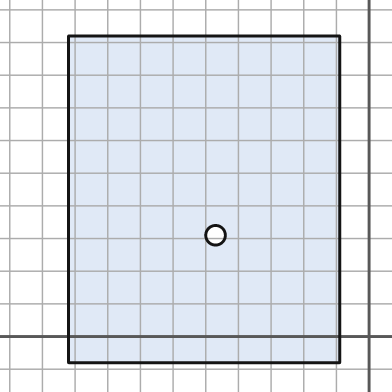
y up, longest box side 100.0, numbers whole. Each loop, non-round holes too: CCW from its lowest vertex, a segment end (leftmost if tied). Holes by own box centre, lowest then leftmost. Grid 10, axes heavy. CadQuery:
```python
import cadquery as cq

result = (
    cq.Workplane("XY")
    .moveTo(-92.0, -8.0)
    .lineTo(-9.0, -8.0)
    .lineTo(-9.0, 92.0)
    .lineTo(-92.0, 92.0)
    .close()
    .moveTo(-47.0, 31.0)
    .circle(3.0)
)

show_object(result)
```